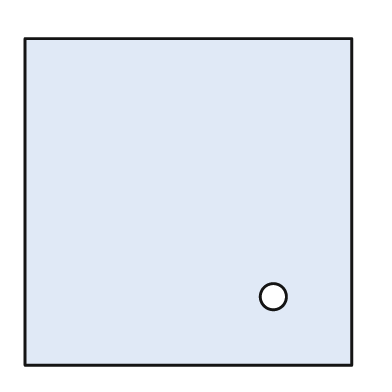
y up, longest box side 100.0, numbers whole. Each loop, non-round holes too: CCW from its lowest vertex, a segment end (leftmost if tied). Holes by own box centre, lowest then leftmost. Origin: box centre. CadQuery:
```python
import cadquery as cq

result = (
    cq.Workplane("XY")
    .moveTo(-50.0, -50.0)
    .lineTo(50.0, -50.0)
    .lineTo(50.0, 50.0)
    .lineTo(-50.0, 50.0)
    .close()
    .moveTo(26.0, -29.0)
    .circle(4.0)
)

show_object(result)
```